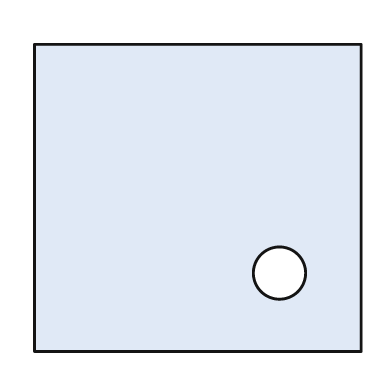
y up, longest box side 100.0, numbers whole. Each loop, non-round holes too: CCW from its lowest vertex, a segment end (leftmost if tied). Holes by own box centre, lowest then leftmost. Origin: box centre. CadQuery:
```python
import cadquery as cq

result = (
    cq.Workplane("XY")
    .moveTo(-50.0, -47.0)
    .lineTo(50.0, -47.0)
    .lineTo(50.0, 47.0)
    .lineTo(-50.0, 47.0)
    .close()
    .moveTo(25.0, -23.0)
    .circle(8.0)
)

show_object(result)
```